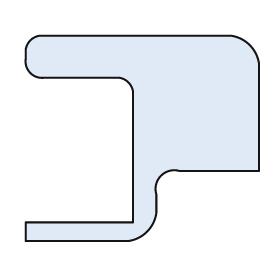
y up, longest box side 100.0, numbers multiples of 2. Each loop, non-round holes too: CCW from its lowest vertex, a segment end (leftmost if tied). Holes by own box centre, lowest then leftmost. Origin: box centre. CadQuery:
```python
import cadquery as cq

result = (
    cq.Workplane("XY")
    .moveTo(-50.0, -44.0)
    .lineTo(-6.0, -44.0)
    .threePointArc((2.0, -40.0), (6.0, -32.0))
    .lineTo(6.0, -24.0)
    .threePointArc((8.0, -16.0), (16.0, -14.0))
    .lineTo(50.0, -14.0)
    .lineTo(50.0, 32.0)
    .threePointArc((46.0, 40.0), (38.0, 44.0))
    .lineTo(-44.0, 44.0)
    .threePointArc((-48.0, 42.0), (-50.0, 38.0))
    .lineTo(-50.0, 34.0)
    .threePointArc((-48.0, 28.0), (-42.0, 26.0))
    .lineTo(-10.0, 26.0)
    .threePointArc((-6.0, 24.0), (-4.0, 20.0))
    .lineTo(-4.0, -36.0)
    .lineTo(-50.0, -36.0)
    .close()
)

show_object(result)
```